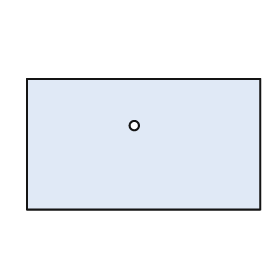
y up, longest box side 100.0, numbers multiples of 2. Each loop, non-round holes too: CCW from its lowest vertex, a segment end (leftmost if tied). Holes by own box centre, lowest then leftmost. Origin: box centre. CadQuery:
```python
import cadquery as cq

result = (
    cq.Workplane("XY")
    .moveTo(-50.0, -28.0)
    .lineTo(50.0, -28.0)
    .lineTo(50.0, 28.0)
    .lineTo(-50.0, 28.0)
    .close()
    .moveTo(-4.0, 8.0)
    .circle(2.0)
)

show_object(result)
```